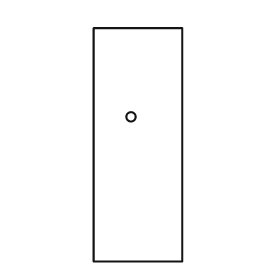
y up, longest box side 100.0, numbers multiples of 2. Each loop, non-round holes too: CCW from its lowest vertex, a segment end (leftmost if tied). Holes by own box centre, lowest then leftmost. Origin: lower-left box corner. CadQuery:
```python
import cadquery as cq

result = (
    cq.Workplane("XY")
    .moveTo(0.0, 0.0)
    .lineTo(38.0, 0.0)
    .lineTo(38.0, 100.0)
    .lineTo(0.0, 100.0)
    .close()
    .moveTo(16.0, 62.0)
    .circle(2.0)
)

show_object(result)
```